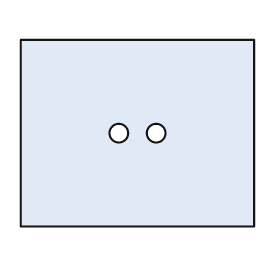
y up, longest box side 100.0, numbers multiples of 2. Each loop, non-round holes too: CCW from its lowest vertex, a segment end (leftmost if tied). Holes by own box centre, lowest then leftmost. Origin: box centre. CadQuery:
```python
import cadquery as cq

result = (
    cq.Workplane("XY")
    .moveTo(-50.0, -40.0)
    .lineTo(50.0, -40.0)
    .lineTo(50.0, 40.0)
    .lineTo(-50.0, 40.0)
    .close()
    .moveTo(-8.0, 0.0)
    .circle(4.0)
    .moveTo(8.0, 0.0)
    .circle(4.0)
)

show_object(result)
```